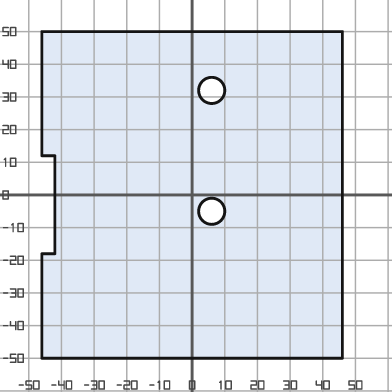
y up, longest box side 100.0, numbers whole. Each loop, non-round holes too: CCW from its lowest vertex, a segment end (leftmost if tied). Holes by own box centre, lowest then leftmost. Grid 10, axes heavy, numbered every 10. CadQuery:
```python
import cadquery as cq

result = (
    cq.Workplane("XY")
    .moveTo(-46.0, -50.0)
    .lineTo(46.0, -50.0)
    .lineTo(46.0, 50.0)
    .lineTo(-46.0, 50.0)
    .lineTo(-46.0, 12.0)
    .lineTo(-42.0, 12.0)
    .lineTo(-42.0, -18.0)
    .lineTo(-46.0, -18.0)
    .close()
    .moveTo(6.0, -5.0)
    .circle(4.0)
    .moveTo(6.0, 32.0)
    .circle(4.0)
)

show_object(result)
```